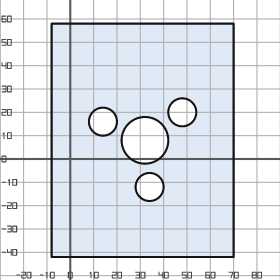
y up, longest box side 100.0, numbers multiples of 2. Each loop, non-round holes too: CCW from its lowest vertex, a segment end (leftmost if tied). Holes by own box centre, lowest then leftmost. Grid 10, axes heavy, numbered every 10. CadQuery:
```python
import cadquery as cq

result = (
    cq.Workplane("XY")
    .moveTo(-8.0, -42.0)
    .lineTo(70.0, -42.0)
    .lineTo(70.0, 58.0)
    .lineTo(-8.0, 58.0)
    .close()
    .moveTo(34.0, -12.0)
    .circle(6.0)
    .moveTo(32.0, 8.0)
    .circle(10.0)
    .moveTo(14.0, 16.0)
    .circle(6.0)
    .moveTo(48.0, 20.0)
    .circle(6.0)
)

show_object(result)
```